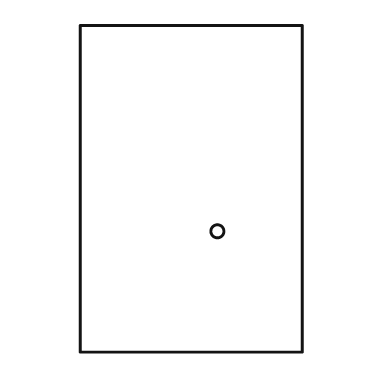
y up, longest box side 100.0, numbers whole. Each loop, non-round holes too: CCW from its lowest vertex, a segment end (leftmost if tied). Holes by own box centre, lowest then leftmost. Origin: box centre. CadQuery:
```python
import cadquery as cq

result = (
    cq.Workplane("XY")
    .moveTo(-34.0, -50.0)
    .lineTo(34.0, -50.0)
    .lineTo(34.0, 50.0)
    .lineTo(-34.0, 50.0)
    .close()
    .moveTo(8.0, -13.0)
    .circle(2.0)
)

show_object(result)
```